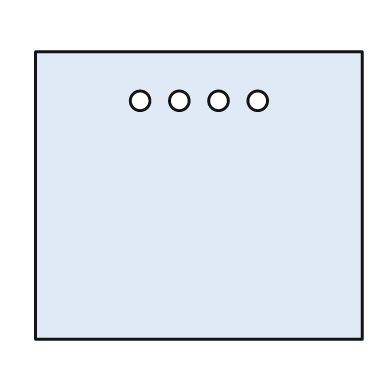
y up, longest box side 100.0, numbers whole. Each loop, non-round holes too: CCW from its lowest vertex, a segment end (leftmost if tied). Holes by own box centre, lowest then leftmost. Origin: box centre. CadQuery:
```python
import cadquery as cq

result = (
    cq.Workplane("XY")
    .moveTo(-50.0, -44.0)
    .lineTo(50.0, -44.0)
    .lineTo(50.0, 44.0)
    .lineTo(-50.0, 44.0)
    .close()
    .moveTo(-18.0, 29.0)
    .circle(3.0)
    .moveTo(-6.0, 29.0)
    .circle(3.0)
    .moveTo(6.0, 29.0)
    .circle(3.0)
    .moveTo(18.0, 29.0)
    .circle(3.0)
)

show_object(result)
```